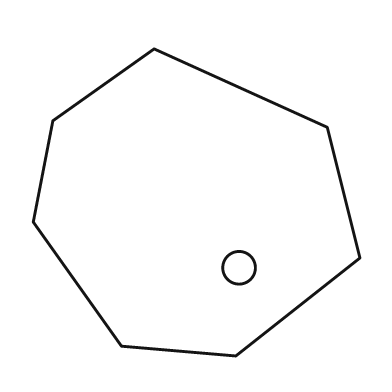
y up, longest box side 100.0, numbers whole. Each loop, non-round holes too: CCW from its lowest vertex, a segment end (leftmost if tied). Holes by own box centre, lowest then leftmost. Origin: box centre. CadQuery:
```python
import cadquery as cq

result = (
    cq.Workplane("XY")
    .moveTo(12.0, -47.0)
    .lineTo(50.0, -17.0)
    .lineTo(40.0, 23.0)
    .lineTo(-13.0, 47.0)
    .lineTo(-44.0, 25.0)
    .lineTo(-50.0, -6.0)
    .lineTo(-23.0, -44.0)
    .close()
    .moveTo(13.0, -20.0)
    .circle(5.0)
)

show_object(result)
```